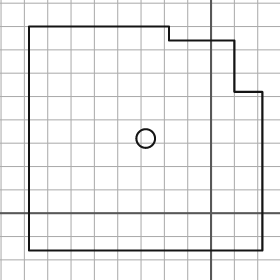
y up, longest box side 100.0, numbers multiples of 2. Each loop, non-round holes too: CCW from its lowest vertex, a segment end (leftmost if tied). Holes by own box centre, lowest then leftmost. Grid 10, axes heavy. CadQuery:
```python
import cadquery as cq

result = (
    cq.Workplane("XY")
    .moveTo(-78.0, -16.0)
    .lineTo(22.0, -16.0)
    .lineTo(22.0, 52.0)
    .lineTo(10.0, 52.0)
    .lineTo(10.0, 74.0)
    .lineTo(-18.0, 74.0)
    .lineTo(-18.0, 80.0)
    .lineTo(-78.0, 80.0)
    .close()
    .moveTo(-28.0, 32.0)
    .circle(4.0)
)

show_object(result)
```